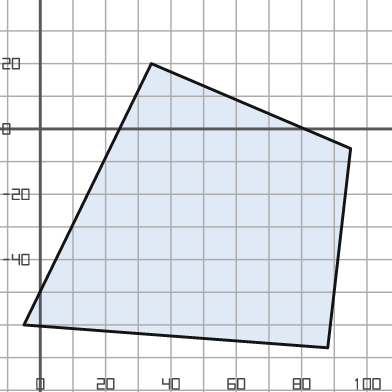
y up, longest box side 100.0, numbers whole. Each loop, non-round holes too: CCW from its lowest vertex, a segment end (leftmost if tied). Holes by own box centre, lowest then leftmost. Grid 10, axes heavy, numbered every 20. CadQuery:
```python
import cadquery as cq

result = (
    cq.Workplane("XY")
    .moveTo(88.0, -67.0)
    .lineTo(95.0, -6.0)
    .lineTo(34.0, 20.0)
    .lineTo(-5.0, -60.0)
    .close()
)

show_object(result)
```